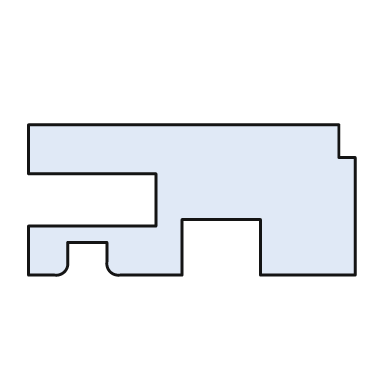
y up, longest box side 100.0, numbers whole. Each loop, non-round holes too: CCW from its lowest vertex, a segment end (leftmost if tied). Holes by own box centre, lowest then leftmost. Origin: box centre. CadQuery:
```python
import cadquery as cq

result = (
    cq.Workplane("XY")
    .moveTo(-50.0, -23.0)
    .lineTo(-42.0, -23.0)
    .threePointArc((-39.0, -22.0), (-38.0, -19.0))
    .lineTo(-38.0, -13.0)
    .lineTo(-26.0, -13.0)
    .lineTo(-26.0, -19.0)
    .threePointArc((-25.0, -22.0), (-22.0, -23.0))
    .lineTo(-3.0, -23.0)
    .lineTo(-3.0, -6.0)
    .lineTo(21.0, -6.0)
    .lineTo(21.0, -23.0)
    .lineTo(50.0, -23.0)
    .lineTo(50.0, 13.0)
    .lineTo(45.0, 13.0)
    .lineTo(45.0, 23.0)
    .lineTo(-50.0, 23.0)
    .lineTo(-50.0, 8.0)
    .lineTo(-11.0, 8.0)
    .lineTo(-11.0, -8.0)
    .lineTo(-50.0, -8.0)
    .close()
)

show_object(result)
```